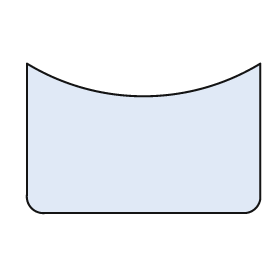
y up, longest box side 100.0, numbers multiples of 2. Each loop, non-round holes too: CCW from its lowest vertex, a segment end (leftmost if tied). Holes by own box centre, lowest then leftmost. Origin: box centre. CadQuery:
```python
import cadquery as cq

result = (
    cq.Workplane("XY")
    .moveTo(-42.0, -32.0)
    .lineTo(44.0, -32.0)
    .threePointArc((48.0, -30.0), (50.0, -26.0))
    .lineTo(50.0, 32.0)
    .threePointArc((0.0, 18.0), (-50.0, 32.0))
    .lineTo(-50.0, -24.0)
    .threePointArc((-48.0, -30.0), (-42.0, -32.0))
    .close()
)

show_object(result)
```